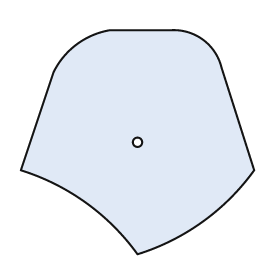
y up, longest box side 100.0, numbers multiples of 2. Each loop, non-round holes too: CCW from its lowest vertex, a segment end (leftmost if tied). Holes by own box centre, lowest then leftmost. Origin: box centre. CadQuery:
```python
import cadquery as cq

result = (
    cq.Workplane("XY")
    .moveTo(0.0, -48.0)
    .threePointArc((28.0, -34.0), (50.0, -12.0))
    .lineTo(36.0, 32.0)
    .threePointArc((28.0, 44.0), (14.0, 48.0))
    .lineTo(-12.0, 48.0)
    .threePointArc((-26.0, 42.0), (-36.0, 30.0))
    .lineTo(-50.0, -12.0)
    .threePointArc((-22.0, -26.0), (0.0, -48.0))
    .close()
    .moveTo(0.0, 0.0)
    .circle(2.0)
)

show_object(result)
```